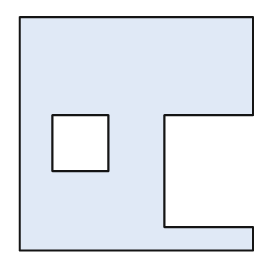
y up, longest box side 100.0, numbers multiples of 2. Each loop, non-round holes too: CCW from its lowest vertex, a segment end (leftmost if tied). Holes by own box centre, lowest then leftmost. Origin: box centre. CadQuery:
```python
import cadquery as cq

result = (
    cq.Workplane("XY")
    .moveTo(-50.0, -50.0)
    .lineTo(50.0, -50.0)
    .lineTo(50.0, -40.0)
    .lineTo(12.0, -40.0)
    .lineTo(12.0, 8.0)
    .lineTo(50.0, 8.0)
    .lineTo(50.0, 50.0)
    .lineTo(-50.0, 50.0)
    .close()
    .moveTo(-36.0, -16.0)
    .lineTo(-12.0, -16.0)
    .lineTo(-12.0, 8.0)
    .lineTo(-36.0, 8.0)
    .close()
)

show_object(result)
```